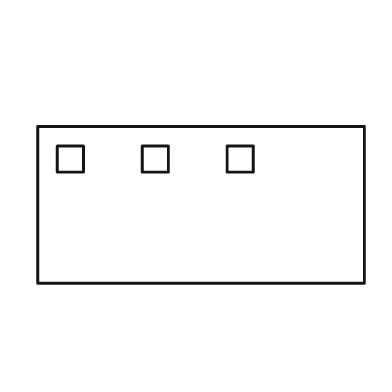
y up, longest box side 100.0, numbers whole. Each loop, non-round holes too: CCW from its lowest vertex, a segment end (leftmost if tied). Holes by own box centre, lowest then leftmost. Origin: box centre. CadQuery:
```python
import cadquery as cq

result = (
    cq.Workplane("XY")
    .moveTo(-50.0, -24.0)
    .lineTo(50.0, -24.0)
    .lineTo(50.0, 24.0)
    .lineTo(-50.0, 24.0)
    .close()
    .moveTo(-44.0, 10.0)
    .lineTo(-36.0, 10.0)
    .lineTo(-36.0, 18.0)
    .lineTo(-44.0, 18.0)
    .close()
    .moveTo(-18.0, 10.0)
    .lineTo(-10.0, 10.0)
    .lineTo(-10.0, 18.0)
    .lineTo(-18.0, 18.0)
    .close()
    .moveTo(8.0, 10.0)
    .lineTo(16.0, 10.0)
    .lineTo(16.0, 18.0)
    .lineTo(8.0, 18.0)
    .close()
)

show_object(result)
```